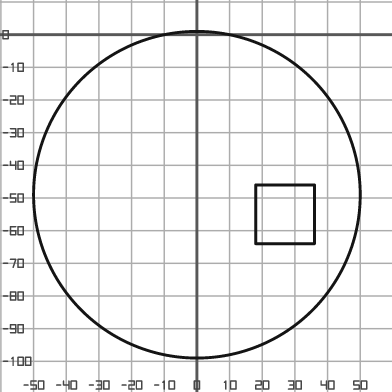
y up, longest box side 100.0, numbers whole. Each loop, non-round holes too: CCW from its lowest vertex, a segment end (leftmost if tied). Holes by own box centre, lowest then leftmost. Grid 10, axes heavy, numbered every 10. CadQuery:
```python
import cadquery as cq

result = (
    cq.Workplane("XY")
    .moveTo(0.0, -49.0)
    .circle(50.0)
    .moveTo(18.0, -64.0)
    .lineTo(36.0, -64.0)
    .lineTo(36.0, -46.0)
    .lineTo(18.0, -46.0)
    .close()
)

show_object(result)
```